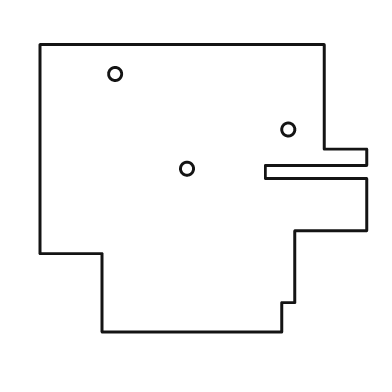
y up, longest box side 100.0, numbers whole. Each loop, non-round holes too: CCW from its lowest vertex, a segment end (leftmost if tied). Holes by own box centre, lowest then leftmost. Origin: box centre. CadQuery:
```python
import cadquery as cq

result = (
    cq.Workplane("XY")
    .moveTo(-31.0, -44.0)
    .lineTo(24.0, -44.0)
    .lineTo(24.0, -35.0)
    .lineTo(28.0, -35.0)
    .lineTo(28.0, -13.0)
    .lineTo(50.0, -13.0)
    .lineTo(50.0, 3.0)
    .lineTo(19.0, 3.0)
    .lineTo(19.0, 7.0)
    .lineTo(50.0, 7.0)
    .lineTo(50.0, 12.0)
    .lineTo(37.0, 12.0)
    .lineTo(37.0, 44.0)
    .lineTo(-50.0, 44.0)
    .lineTo(-50.0, -20.0)
    .lineTo(-31.0, -20.0)
    .close()
    .moveTo(-5.0, 6.0)
    .circle(2.0)
    .moveTo(26.0, 18.0)
    .circle(2.0)
    .moveTo(-27.0, 35.0)
    .circle(2.0)
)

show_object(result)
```